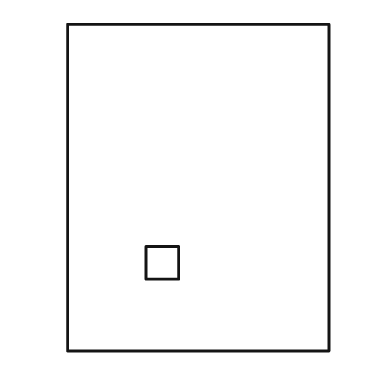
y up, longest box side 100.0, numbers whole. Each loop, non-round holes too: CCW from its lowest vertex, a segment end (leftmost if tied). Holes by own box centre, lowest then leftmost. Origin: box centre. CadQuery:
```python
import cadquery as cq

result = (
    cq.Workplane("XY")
    .moveTo(-40.0, -50.0)
    .lineTo(40.0, -50.0)
    .lineTo(40.0, 50.0)
    .lineTo(-40.0, 50.0)
    .close()
    .moveTo(-16.0, -28.0)
    .lineTo(-6.0, -28.0)
    .lineTo(-6.0, -18.0)
    .lineTo(-16.0, -18.0)
    .close()
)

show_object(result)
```